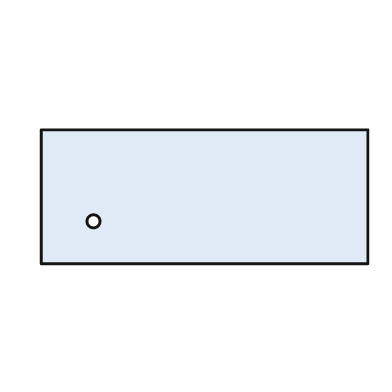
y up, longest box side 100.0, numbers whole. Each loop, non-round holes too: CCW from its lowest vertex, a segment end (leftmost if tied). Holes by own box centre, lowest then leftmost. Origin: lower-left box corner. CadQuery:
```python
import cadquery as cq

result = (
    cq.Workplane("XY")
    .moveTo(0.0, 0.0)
    .lineTo(100.0, 0.0)
    .lineTo(100.0, 41.0)
    .lineTo(0.0, 41.0)
    .close()
    .moveTo(16.0, 13.0)
    .circle(2.0)
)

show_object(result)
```